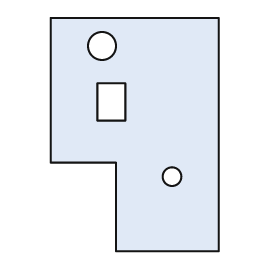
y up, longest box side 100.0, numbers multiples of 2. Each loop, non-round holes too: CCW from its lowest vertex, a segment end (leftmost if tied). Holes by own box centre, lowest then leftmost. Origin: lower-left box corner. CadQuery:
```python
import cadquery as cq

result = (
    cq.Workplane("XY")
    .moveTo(28.0, 0.0)
    .lineTo(72.0, 0.0)
    .lineTo(72.0, 100.0)
    .lineTo(0.0, 100.0)
    .lineTo(0.0, 38.0)
    .lineTo(28.0, 38.0)
    .close()
    .moveTo(52.0, 32.0)
    .circle(4.0)
    .moveTo(20.0, 56.0)
    .lineTo(32.0, 56.0)
    .lineTo(32.0, 72.0)
    .lineTo(20.0, 72.0)
    .close()
    .moveTo(22.0, 88.0)
    .circle(6.0)
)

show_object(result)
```